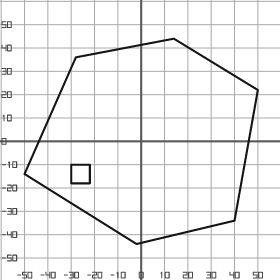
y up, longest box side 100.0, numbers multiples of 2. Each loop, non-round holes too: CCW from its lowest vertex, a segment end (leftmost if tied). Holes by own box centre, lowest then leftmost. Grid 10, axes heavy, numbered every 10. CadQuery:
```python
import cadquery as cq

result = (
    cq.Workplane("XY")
    .moveTo(-2.0, -44.0)
    .lineTo(40.0, -34.0)
    .lineTo(50.0, 22.0)
    .lineTo(14.0, 44.0)
    .lineTo(-28.0, 36.0)
    .lineTo(-50.0, -14.0)
    .close()
    .moveTo(-30.0, -18.0)
    .lineTo(-22.0, -18.0)
    .lineTo(-22.0, -10.0)
    .lineTo(-30.0, -10.0)
    .close()
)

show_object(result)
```